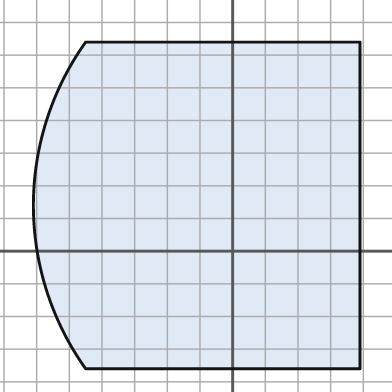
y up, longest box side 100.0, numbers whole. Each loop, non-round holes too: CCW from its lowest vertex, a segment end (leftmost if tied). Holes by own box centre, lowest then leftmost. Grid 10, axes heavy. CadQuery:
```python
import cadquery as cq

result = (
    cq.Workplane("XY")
    .moveTo(-45.0, -36.0)
    .lineTo(39.0, -36.0)
    .lineTo(39.0, 64.0)
    .lineTo(-45.0, 64.0)
    .threePointArc((-61.0, 14.0), (-45.0, -36.0))
    .close()
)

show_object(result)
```